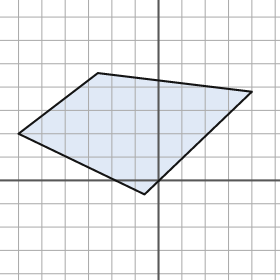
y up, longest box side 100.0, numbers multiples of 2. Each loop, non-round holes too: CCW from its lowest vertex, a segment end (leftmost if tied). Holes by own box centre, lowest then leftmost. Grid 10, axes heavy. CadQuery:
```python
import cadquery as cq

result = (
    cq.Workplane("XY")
    .moveTo(-6.0, -6.0)
    .lineTo(40.0, 38.0)
    .lineTo(-26.0, 46.0)
    .lineTo(-60.0, 20.0)
    .close()
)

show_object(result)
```